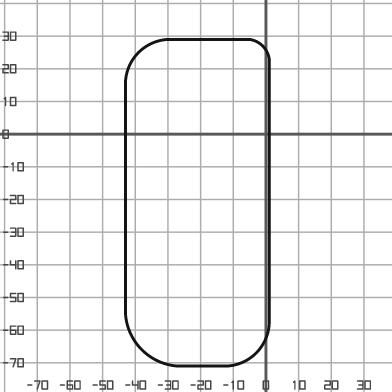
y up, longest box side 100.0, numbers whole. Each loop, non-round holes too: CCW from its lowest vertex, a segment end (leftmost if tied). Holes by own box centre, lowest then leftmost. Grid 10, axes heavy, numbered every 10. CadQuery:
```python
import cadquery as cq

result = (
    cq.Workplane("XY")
    .moveTo(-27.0, -71.0)
    .lineTo(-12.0, -71.0)
    .threePointArc((-3.0, -67.0), (1.0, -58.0))
    .lineTo(1.0, 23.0)
    .threePointArc((-1.0, 27.0), (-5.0, 29.0))
    .lineTo(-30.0, 29.0)
    .threePointArc((-39.0, 25.0), (-43.0, 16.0))
    .lineTo(-43.0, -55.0)
    .threePointArc((-38.0, -66.0), (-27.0, -71.0))
    .close()
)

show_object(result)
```